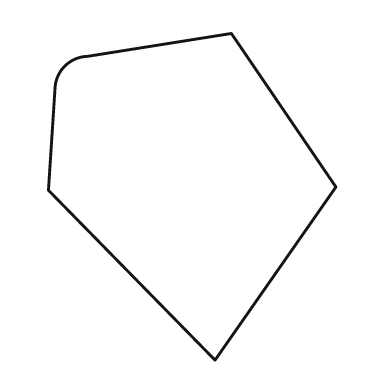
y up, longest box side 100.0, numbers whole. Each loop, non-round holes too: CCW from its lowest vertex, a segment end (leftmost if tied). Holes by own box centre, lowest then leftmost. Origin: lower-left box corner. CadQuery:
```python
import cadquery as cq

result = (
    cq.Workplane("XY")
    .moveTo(51.0, 0.0)
    .lineTo(88.0, 53.0)
    .lineTo(56.0, 100.0)
    .lineTo(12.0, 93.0)
    .threePointArc((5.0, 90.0), (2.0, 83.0))
    .lineTo(0.0, 52.0)
    .close()
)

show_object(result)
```